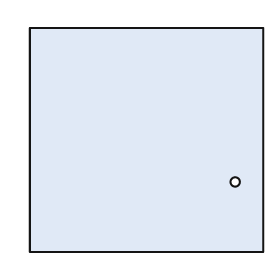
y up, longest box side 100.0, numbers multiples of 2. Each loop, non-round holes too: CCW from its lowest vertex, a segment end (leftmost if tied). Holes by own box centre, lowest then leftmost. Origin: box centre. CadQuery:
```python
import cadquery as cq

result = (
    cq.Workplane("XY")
    .moveTo(-50.0, -48.0)
    .lineTo(50.0, -48.0)
    .lineTo(50.0, 48.0)
    .lineTo(-50.0, 48.0)
    .close()
    .moveTo(38.0, -18.0)
    .circle(2.0)
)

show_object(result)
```